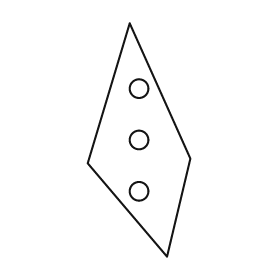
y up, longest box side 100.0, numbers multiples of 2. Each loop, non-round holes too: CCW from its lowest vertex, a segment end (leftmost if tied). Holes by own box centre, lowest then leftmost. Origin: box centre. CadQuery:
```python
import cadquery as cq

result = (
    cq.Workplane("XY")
    .moveTo(12.0, -50.0)
    .lineTo(22.0, -8.0)
    .lineTo(-4.0, 50.0)
    .lineTo(-22.0, -10.0)
    .close()
    .moveTo(0.0, -22.0)
    .circle(4.0)
    .moveTo(0.0, 0.0)
    .circle(4.0)
    .moveTo(0.0, 22.0)
    .circle(4.0)
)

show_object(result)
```